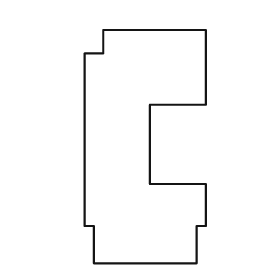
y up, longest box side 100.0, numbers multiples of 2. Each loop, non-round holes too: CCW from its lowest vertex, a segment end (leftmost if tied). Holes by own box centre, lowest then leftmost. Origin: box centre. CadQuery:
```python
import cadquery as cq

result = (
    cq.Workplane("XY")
    .moveTo(-22.0, -50.0)
    .lineTo(22.0, -50.0)
    .lineTo(22.0, -34.0)
    .lineTo(26.0, -34.0)
    .lineTo(26.0, -16.0)
    .lineTo(2.0, -16.0)
    .lineTo(2.0, 18.0)
    .lineTo(26.0, 18.0)
    .lineTo(26.0, 50.0)
    .lineTo(-18.0, 50.0)
    .lineTo(-18.0, 40.0)
    .lineTo(-26.0, 40.0)
    .lineTo(-26.0, -34.0)
    .lineTo(-22.0, -34.0)
    .close()
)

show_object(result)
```